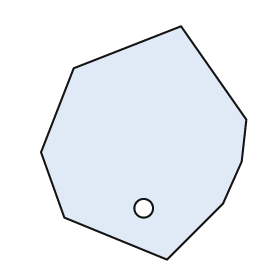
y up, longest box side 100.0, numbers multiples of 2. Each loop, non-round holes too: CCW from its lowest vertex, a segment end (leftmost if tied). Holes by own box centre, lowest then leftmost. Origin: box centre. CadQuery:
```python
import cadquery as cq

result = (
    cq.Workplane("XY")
    .moveTo(10.0, -50.0)
    .lineTo(34.0, -26.0)
    .lineTo(42.0, -8.0)
    .lineTo(44.0, 10.0)
    .lineTo(16.0, 50.0)
    .lineTo(-30.0, 32.0)
    .lineTo(-44.0, -4.0)
    .lineTo(-34.0, -32.0)
    .close()
    .moveTo(0.0, -28.0)
    .circle(4.0)
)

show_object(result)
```